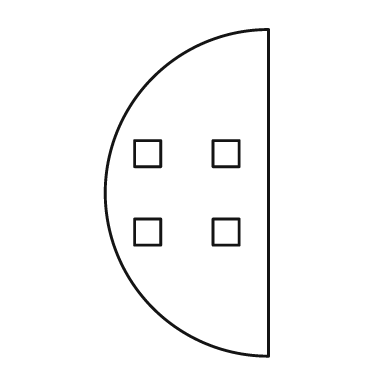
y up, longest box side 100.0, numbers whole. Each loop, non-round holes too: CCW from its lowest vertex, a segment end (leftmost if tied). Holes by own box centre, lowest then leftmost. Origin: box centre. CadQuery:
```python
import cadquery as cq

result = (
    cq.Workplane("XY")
    .moveTo(25.0, -50.0)
    .lineTo(25.0, 50.0)
    .threePointArc((-25.0, 0.0), (25.0, -50.0))
    .close()
    .moveTo(-16.0, -16.0)
    .lineTo(-8.0, -16.0)
    .lineTo(-8.0, -8.0)
    .lineTo(-16.0, -8.0)
    .close()
    .moveTo(8.0, -16.0)
    .lineTo(16.0, -16.0)
    .lineTo(16.0, -8.0)
    .lineTo(8.0, -8.0)
    .close()
    .moveTo(-16.0, 8.0)
    .lineTo(-8.0, 8.0)
    .lineTo(-8.0, 16.0)
    .lineTo(-16.0, 16.0)
    .close()
    .moveTo(8.0, 8.0)
    .lineTo(16.0, 8.0)
    .lineTo(16.0, 16.0)
    .lineTo(8.0, 16.0)
    .close()
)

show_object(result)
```